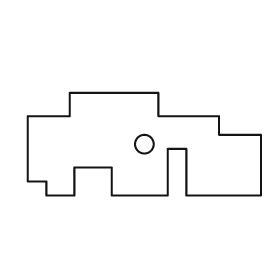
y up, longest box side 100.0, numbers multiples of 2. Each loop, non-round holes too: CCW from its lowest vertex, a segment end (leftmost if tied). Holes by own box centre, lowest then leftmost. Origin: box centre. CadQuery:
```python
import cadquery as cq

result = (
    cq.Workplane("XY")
    .moveTo(-42.0, -22.0)
    .lineTo(-30.0, -22.0)
    .lineTo(-30.0, -10.0)
    .lineTo(-14.0, -10.0)
    .lineTo(-14.0, -22.0)
    .lineTo(10.0, -22.0)
    .lineTo(10.0, -2.0)
    .lineTo(18.0, -2.0)
    .lineTo(18.0, -22.0)
    .lineTo(50.0, -22.0)
    .lineTo(50.0, 4.0)
    .lineTo(32.0, 4.0)
    .lineTo(32.0, 12.0)
    .lineTo(6.0, 12.0)
    .lineTo(6.0, 22.0)
    .lineTo(-32.0, 22.0)
    .lineTo(-32.0, 12.0)
    .lineTo(-50.0, 12.0)
    .lineTo(-50.0, -16.0)
    .lineTo(-42.0, -16.0)
    .close()
    .moveTo(0.0, 0.0)
    .circle(4.0)
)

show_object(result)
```